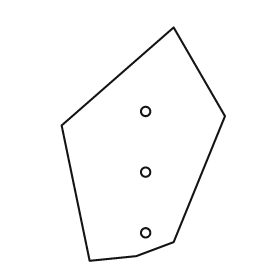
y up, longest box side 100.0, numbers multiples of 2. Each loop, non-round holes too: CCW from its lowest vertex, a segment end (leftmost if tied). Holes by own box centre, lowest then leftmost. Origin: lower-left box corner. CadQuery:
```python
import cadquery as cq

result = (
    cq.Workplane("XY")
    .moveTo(12.0, 0.0)
    .lineTo(32.0, 2.0)
    .lineTo(48.0, 8.0)
    .lineTo(70.0, 62.0)
    .lineTo(48.0, 100.0)
    .lineTo(0.0, 58.0)
    .close()
    .moveTo(36.0, 12.0)
    .circle(2.0)
    .moveTo(36.0, 38.0)
    .circle(2.0)
    .moveTo(36.0, 64.0)
    .circle(2.0)
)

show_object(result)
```